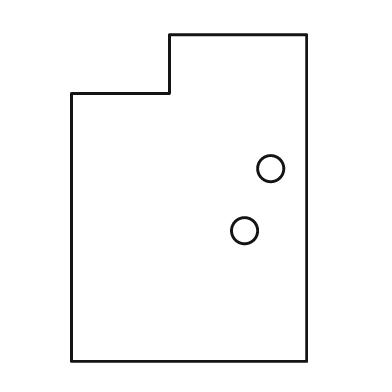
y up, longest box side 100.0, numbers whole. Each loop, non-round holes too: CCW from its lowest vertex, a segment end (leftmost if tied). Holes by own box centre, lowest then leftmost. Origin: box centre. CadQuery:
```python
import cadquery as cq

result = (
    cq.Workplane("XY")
    .moveTo(-36.0, -50.0)
    .lineTo(36.0, -50.0)
    .lineTo(36.0, 50.0)
    .lineTo(-6.0, 50.0)
    .lineTo(-6.0, 32.0)
    .lineTo(-36.0, 32.0)
    .close()
    .moveTo(17.0, -10.0)
    .circle(4.0)
    .moveTo(25.0, 9.0)
    .circle(4.0)
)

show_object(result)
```